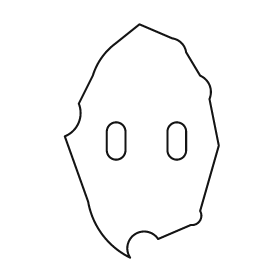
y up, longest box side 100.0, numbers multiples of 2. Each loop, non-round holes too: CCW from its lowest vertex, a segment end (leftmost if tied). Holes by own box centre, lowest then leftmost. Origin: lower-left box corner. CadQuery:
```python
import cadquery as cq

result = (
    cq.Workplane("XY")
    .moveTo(28.0, 0.0)
    .threePointArc((30.0, 10.0), (40.0, 8.0))
    .lineTo(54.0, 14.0)
    .threePointArc((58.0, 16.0), (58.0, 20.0))
    .lineTo(66.0, 48.0)
    .lineTo(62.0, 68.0)
    .threePointArc((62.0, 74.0), (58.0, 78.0))
    .lineTo(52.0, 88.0)
    .threePointArc((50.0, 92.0), (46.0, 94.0))
    .lineTo(32.0, 100.0)
    .lineTo(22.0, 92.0)
    .threePointArc((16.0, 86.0), (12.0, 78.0))
    .lineTo(6.0, 66.0)
    .threePointArc((6.0, 58.0), (0.0, 52.0))
    .lineTo(10.0, 24.0)
    .threePointArc((16.0, 10.0), (28.0, 0.0))
    .close()
    .moveTo(18.0, 46.0)
    .threePointArc((22.0, 42.0), (26.0, 46.0))
    .lineTo(26.0, 54.0)
    .threePointArc((22.0, 58.0), (18.0, 54.0))
    .close()
    .moveTo(44.0, 46.0)
    .threePointArc((48.0, 42.0), (52.0, 46.0))
    .lineTo(52.0, 54.0)
    .threePointArc((48.0, 58.0), (44.0, 54.0))
    .close()
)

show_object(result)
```